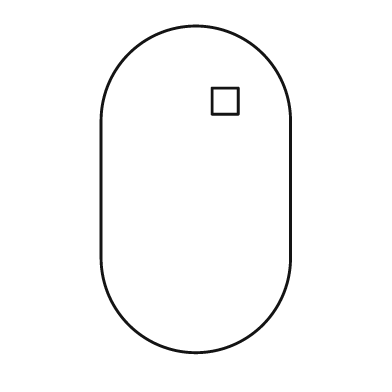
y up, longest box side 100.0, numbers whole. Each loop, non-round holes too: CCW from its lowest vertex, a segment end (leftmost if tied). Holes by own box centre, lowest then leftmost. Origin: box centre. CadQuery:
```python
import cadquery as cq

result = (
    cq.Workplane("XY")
    .moveTo(-29.0, -21.0)
    .threePointArc((0.0, -50.0), (29.0, -21.0))
    .lineTo(29.0, 21.0)
    .threePointArc((0.0, 50.0), (-29.0, 21.0))
    .close()
    .moveTo(5.0, 23.0)
    .lineTo(13.0, 23.0)
    .lineTo(13.0, 31.0)
    .lineTo(5.0, 31.0)
    .close()
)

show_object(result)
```